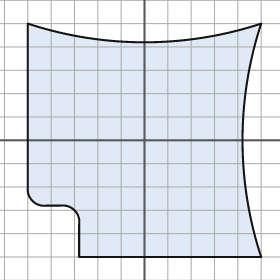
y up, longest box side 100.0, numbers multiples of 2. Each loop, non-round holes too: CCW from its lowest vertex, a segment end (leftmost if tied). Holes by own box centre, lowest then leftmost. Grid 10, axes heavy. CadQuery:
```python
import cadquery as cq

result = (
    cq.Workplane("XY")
    .moveTo(-28.0, -50.0)
    .lineTo(50.0, -50.0)
    .threePointArc((42.0, 0.0), (50.0, 50.0))
    .threePointArc((0.0, 42.0), (-50.0, 50.0))
    .lineTo(-50.0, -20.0)
    .threePointArc((-48.0, -26.0), (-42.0, -28.0))
    .lineTo(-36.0, -28.0)
    .threePointArc((-30.0, -30.0), (-28.0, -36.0))
    .close()
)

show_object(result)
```